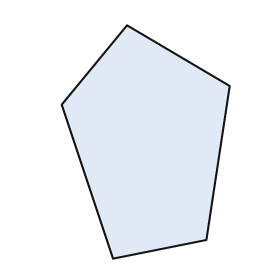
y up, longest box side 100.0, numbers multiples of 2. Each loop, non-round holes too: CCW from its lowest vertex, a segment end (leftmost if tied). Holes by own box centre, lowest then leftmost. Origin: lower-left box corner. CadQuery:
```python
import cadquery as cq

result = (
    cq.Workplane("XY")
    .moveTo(22.0, 0.0)
    .lineTo(62.0, 8.0)
    .lineTo(72.0, 74.0)
    .lineTo(28.0, 100.0)
    .lineTo(0.0, 66.0)
    .close()
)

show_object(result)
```